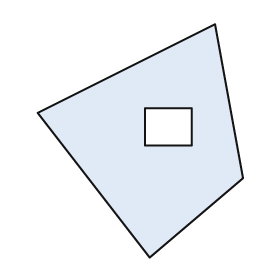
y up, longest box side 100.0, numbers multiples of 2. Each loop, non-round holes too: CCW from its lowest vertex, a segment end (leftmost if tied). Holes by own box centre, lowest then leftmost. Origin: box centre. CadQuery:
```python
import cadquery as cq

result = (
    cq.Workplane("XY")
    .moveTo(4.0, -50.0)
    .lineTo(44.0, -16.0)
    .lineTo(32.0, 50.0)
    .lineTo(-44.0, 12.0)
    .close()
    .moveTo(2.0, -2.0)
    .lineTo(22.0, -2.0)
    .lineTo(22.0, 14.0)
    .lineTo(2.0, 14.0)
    .close()
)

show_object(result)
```